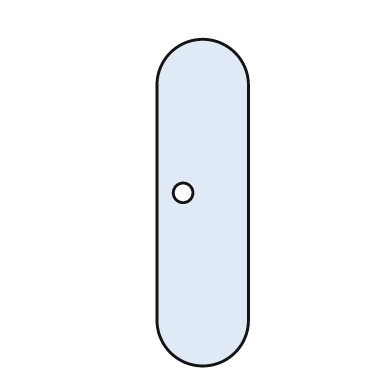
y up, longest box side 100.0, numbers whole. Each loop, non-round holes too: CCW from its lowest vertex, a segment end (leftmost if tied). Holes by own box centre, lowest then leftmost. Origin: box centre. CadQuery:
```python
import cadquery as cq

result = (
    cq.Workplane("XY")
    .moveTo(-14.0, -36.0)
    .threePointArc((0.0, -50.0), (14.0, -36.0))
    .lineTo(14.0, 36.0)
    .threePointArc((0.0, 50.0), (-14.0, 36.0))
    .close()
    .moveTo(-6.0, 3.0)
    .circle(3.0)
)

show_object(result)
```